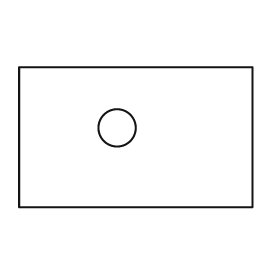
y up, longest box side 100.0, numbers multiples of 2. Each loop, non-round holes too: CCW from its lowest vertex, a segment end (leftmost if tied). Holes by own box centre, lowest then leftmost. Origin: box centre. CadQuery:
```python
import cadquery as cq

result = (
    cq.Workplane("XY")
    .moveTo(-50.0, -30.0)
    .lineTo(50.0, -30.0)
    .lineTo(50.0, 30.0)
    .lineTo(-50.0, 30.0)
    .close()
    .moveTo(-8.0, 4.0)
    .circle(8.0)
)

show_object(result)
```